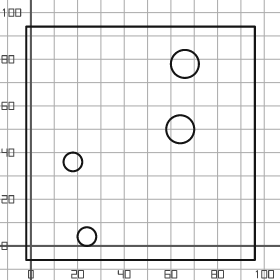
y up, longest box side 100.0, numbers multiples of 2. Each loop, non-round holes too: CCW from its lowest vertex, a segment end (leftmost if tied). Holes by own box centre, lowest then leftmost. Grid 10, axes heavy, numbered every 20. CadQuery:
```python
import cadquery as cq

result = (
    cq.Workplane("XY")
    .moveTo(-2.0, -6.0)
    .lineTo(96.0, -6.0)
    .lineTo(96.0, 94.0)
    .lineTo(-2.0, 94.0)
    .close()
    .moveTo(24.0, 4.0)
    .circle(4.0)
    .moveTo(18.0, 36.0)
    .circle(4.0)
    .moveTo(64.0, 50.0)
    .circle(6.0)
    .moveTo(66.0, 78.0)
    .circle(6.0)
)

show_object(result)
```